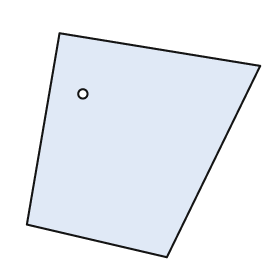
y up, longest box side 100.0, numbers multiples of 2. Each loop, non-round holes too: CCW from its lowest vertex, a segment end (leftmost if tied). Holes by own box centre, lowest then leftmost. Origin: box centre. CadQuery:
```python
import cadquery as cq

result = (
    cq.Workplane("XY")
    .moveTo(10.0, -48.0)
    .lineTo(50.0, 34.0)
    .lineTo(-36.0, 48.0)
    .lineTo(-50.0, -34.0)
    .close()
    .moveTo(-26.0, 22.0)
    .circle(2.0)
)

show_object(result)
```